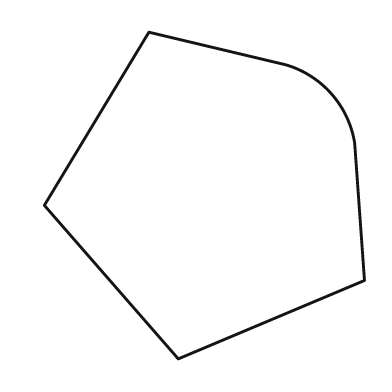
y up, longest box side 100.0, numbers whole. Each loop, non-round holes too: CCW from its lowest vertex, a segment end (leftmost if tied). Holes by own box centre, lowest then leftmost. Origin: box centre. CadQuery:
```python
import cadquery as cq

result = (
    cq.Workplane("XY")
    .moveTo(-8.0, -50.0)
    .lineTo(49.0, -26.0)
    .lineTo(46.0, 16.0)
    .threePointArc((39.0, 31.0), (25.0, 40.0))
    .lineTo(-17.0, 50.0)
    .lineTo(-49.0, -3.0)
    .close()
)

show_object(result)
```